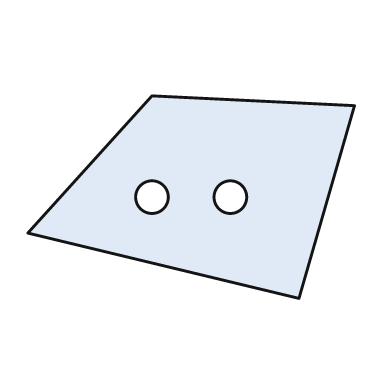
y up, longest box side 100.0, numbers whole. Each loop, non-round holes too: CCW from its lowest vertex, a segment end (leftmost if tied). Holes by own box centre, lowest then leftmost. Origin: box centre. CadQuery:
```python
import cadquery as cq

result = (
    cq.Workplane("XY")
    .moveTo(33.0, -31.0)
    .lineTo(50.0, 28.0)
    .lineTo(-12.0, 31.0)
    .lineTo(-50.0, -11.0)
    .close()
    .moveTo(-12.0, 0.0)
    .circle(5.0)
    .moveTo(12.0, 0.0)
    .circle(5.0)
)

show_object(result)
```